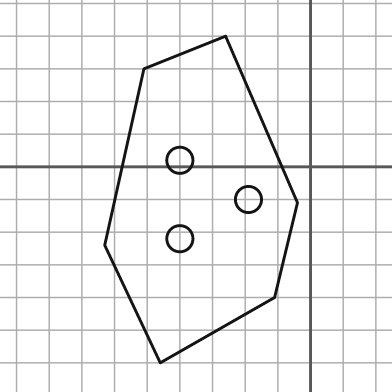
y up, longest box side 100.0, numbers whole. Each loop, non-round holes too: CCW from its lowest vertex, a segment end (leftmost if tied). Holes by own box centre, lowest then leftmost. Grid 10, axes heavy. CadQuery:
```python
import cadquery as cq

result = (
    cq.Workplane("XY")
    .moveTo(-46.0, -60.0)
    .lineTo(-11.0, -40.0)
    .lineTo(-4.0, -11.0)
    .lineTo(-26.0, 40.0)
    .lineTo(-51.0, 30.0)
    .lineTo(-63.0, -24.0)
    .close()
    .moveTo(-40.0, -22.0)
    .circle(4.0)
    .moveTo(-19.0, -10.0)
    .circle(4.0)
    .moveTo(-40.0, 2.0)
    .circle(4.0)
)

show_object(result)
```